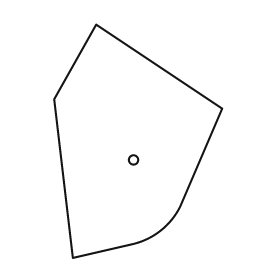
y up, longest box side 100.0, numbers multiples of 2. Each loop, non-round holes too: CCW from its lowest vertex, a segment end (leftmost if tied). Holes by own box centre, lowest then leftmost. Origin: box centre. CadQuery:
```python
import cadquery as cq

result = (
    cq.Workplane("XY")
    .moveTo(-28.0, -50.0)
    .lineTo(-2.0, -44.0)
    .threePointArc((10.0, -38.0), (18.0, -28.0))
    .lineTo(36.0, 14.0)
    .lineTo(-18.0, 50.0)
    .lineTo(-36.0, 18.0)
    .close()
    .moveTo(-2.0, -8.0)
    .circle(2.0)
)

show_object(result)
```